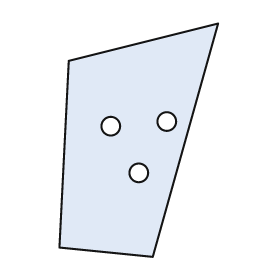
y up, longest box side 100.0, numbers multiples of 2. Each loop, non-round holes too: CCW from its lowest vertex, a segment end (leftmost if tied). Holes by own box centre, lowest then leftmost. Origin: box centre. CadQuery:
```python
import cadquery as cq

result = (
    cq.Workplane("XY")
    .moveTo(6.0, -50.0)
    .lineTo(34.0, 50.0)
    .lineTo(-30.0, 34.0)
    .lineTo(-34.0, -46.0)
    .close()
    .moveTo(0.0, -14.0)
    .circle(4.0)
    .moveTo(-12.0, 6.0)
    .circle(4.0)
    .moveTo(12.0, 8.0)
    .circle(4.0)
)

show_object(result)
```